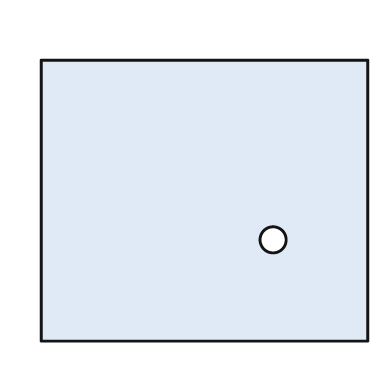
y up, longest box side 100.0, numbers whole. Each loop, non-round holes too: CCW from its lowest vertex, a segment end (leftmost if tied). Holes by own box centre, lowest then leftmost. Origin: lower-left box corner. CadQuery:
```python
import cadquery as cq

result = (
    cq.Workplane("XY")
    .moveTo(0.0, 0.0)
    .lineTo(100.0, 0.0)
    .lineTo(100.0, 86.0)
    .lineTo(0.0, 86.0)
    .close()
    .moveTo(71.0, 31.0)
    .circle(4.0)
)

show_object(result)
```